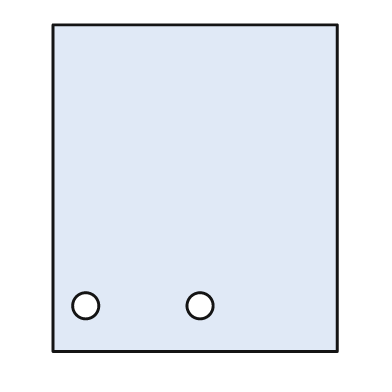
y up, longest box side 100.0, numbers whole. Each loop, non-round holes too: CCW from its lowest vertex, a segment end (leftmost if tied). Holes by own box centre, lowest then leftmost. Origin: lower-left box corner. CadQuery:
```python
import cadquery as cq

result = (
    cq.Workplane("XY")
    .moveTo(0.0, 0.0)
    .lineTo(87.0, 0.0)
    .lineTo(87.0, 100.0)
    .lineTo(0.0, 100.0)
    .close()
    .moveTo(10.0, 14.0)
    .circle(4.0)
    .moveTo(45.0, 14.0)
    .circle(4.0)
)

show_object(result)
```